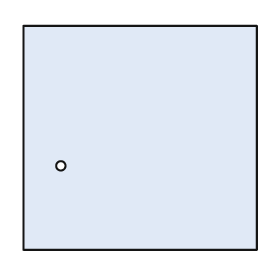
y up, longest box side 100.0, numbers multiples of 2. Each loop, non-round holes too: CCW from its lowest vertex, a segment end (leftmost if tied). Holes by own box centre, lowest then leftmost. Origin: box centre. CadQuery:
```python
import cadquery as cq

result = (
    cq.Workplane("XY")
    .moveTo(-50.0, -48.0)
    .lineTo(50.0, -48.0)
    .lineTo(50.0, 48.0)
    .lineTo(-50.0, 48.0)
    .close()
    .moveTo(-34.0, -12.0)
    .circle(2.0)
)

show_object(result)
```